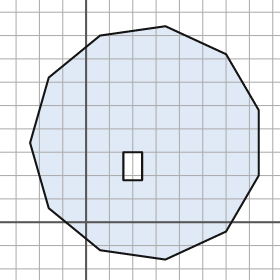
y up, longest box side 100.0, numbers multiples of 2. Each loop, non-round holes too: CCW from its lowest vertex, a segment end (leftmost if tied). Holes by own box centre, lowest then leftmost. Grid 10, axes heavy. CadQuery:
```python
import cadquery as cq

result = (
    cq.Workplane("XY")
    .moveTo(34.0, -16.0)
    .lineTo(60.0, -4.0)
    .lineTo(74.0, 20.0)
    .lineTo(74.0, 48.0)
    .lineTo(60.0, 72.0)
    .lineTo(34.0, 84.0)
    .lineTo(6.0, 80.0)
    .lineTo(-16.0, 62.0)
    .lineTo(-24.0, 34.0)
    .lineTo(-16.0, 6.0)
    .lineTo(6.0, -12.0)
    .close()
    .moveTo(16.0, 18.0)
    .lineTo(24.0, 18.0)
    .lineTo(24.0, 30.0)
    .lineTo(16.0, 30.0)
    .close()
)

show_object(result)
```